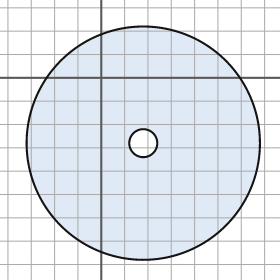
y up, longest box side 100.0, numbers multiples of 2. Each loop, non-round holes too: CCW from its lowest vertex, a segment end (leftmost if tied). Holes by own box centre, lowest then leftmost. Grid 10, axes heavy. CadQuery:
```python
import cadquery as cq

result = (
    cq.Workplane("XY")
    .moveTo(18.0, -28.0)
    .circle(50.0)
    .moveTo(18.0, -28.0)
    .circle(6.0)
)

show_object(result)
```